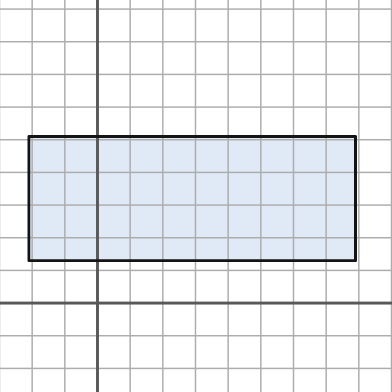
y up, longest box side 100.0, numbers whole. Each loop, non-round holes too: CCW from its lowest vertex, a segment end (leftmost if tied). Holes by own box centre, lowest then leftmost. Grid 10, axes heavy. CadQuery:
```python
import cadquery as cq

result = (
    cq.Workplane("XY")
    .moveTo(-21.0, 13.0)
    .lineTo(79.0, 13.0)
    .lineTo(79.0, 51.0)
    .lineTo(-21.0, 51.0)
    .close()
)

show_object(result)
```